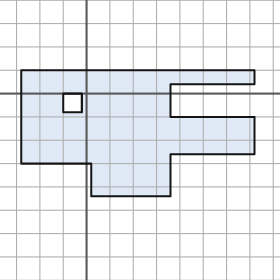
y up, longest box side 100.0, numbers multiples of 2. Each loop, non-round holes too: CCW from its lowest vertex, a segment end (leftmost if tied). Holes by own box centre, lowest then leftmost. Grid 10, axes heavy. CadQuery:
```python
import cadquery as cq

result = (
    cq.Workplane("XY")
    .moveTo(2.0, -44.0)
    .lineTo(36.0, -44.0)
    .lineTo(36.0, -26.0)
    .lineTo(72.0, -26.0)
    .lineTo(72.0, -10.0)
    .lineTo(36.0, -10.0)
    .lineTo(36.0, 4.0)
    .lineTo(72.0, 4.0)
    .lineTo(72.0, 10.0)
    .lineTo(-28.0, 10.0)
    .lineTo(-28.0, -30.0)
    .lineTo(2.0, -30.0)
    .close()
    .moveTo(-10.0, -8.0)
    .lineTo(-2.0, -8.0)
    .lineTo(-2.0, 0.0)
    .lineTo(-10.0, 0.0)
    .close()
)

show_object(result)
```